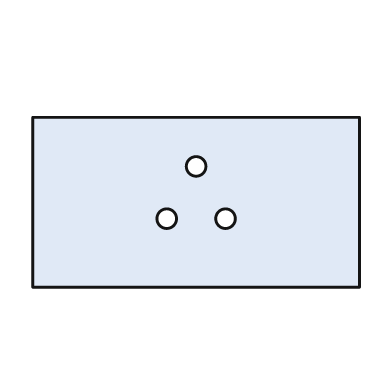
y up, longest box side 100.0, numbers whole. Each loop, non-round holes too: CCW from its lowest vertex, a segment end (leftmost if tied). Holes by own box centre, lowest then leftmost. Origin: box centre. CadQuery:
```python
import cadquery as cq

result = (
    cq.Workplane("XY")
    .moveTo(-50.0, -26.0)
    .lineTo(50.0, -26.0)
    .lineTo(50.0, 26.0)
    .lineTo(-50.0, 26.0)
    .close()
    .moveTo(-9.0, -5.0)
    .circle(3.0)
    .moveTo(9.0, -5.0)
    .circle(3.0)
    .moveTo(0.0, 11.0)
    .circle(3.0)
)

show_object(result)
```